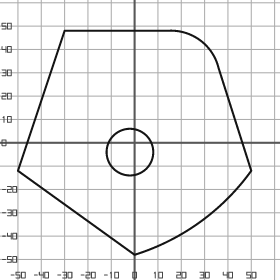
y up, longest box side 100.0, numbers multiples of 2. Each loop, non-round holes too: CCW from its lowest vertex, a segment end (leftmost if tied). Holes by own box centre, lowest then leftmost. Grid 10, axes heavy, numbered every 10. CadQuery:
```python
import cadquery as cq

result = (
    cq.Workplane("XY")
    .moveTo(0.0, -48.0)
    .threePointArc((28.0, -34.0), (50.0, -12.0))
    .lineTo(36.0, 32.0)
    .threePointArc((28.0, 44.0), (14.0, 48.0))
    .lineTo(-30.0, 48.0)
    .lineTo(-50.0, -12.0)
    .close()
    .moveTo(-2.0, -4.0)
    .circle(10.0)
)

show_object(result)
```